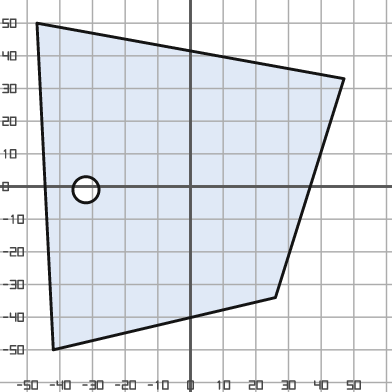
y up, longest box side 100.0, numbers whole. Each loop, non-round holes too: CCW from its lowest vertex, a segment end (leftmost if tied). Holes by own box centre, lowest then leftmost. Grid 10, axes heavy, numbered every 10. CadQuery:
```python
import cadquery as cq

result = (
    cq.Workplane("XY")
    .moveTo(-42.0, -50.0)
    .lineTo(26.0, -34.0)
    .lineTo(47.0, 33.0)
    .lineTo(-47.0, 50.0)
    .close()
    .moveTo(-32.0, -1.0)
    .circle(4.0)
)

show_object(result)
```